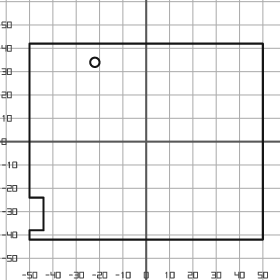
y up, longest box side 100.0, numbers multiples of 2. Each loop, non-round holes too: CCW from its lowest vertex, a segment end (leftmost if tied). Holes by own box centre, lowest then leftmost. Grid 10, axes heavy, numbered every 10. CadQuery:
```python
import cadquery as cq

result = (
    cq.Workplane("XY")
    .moveTo(-50.0, -42.0)
    .lineTo(50.0, -42.0)
    .lineTo(50.0, 42.0)
    .lineTo(-50.0, 42.0)
    .lineTo(-50.0, -24.0)
    .lineTo(-44.0, -24.0)
    .lineTo(-44.0, -38.0)
    .lineTo(-50.0, -38.0)
    .close()
    .moveTo(-22.0, 34.0)
    .circle(2.0)
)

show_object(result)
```